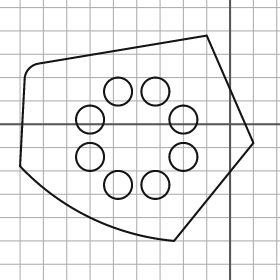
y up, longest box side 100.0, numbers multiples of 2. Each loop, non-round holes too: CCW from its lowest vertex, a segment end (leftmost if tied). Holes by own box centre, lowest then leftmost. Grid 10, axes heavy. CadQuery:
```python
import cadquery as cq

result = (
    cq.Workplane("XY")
    .moveTo(-24.0, -50.0)
    .lineTo(10.0, -8.0)
    .lineTo(-10.0, 38.0)
    .lineTo(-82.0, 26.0)
    .threePointArc((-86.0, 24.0), (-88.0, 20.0))
    .lineTo(-90.0, -18.0)
    .threePointArc((-60.0, -40.0), (-24.0, -50.0))
    .close()
    .moveTo(-48.0, -26.0)
    .circle(6.0)
    .moveTo(-32.0, -26.0)
    .circle(6.0)
    .moveTo(-60.0, -14.0)
    .circle(6.0)
    .moveTo(-20.0, -14.0)
    .circle(6.0)
    .moveTo(-60.0, 2.0)
    .circle(6.0)
    .moveTo(-20.0, 2.0)
    .circle(6.0)
    .moveTo(-48.0, 14.0)
    .circle(6.0)
    .moveTo(-32.0, 14.0)
    .circle(6.0)
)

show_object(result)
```